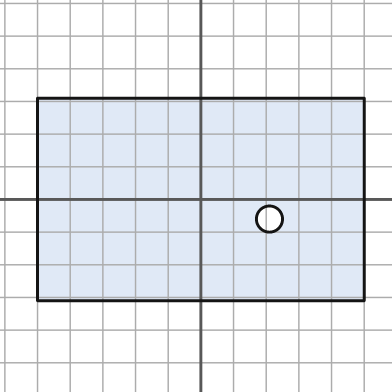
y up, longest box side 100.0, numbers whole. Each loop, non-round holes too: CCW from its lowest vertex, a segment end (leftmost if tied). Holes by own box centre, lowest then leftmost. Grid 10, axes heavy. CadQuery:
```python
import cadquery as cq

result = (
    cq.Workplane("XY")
    .moveTo(-50.0, -31.0)
    .lineTo(50.0, -31.0)
    .lineTo(50.0, 31.0)
    .lineTo(-50.0, 31.0)
    .close()
    .moveTo(21.0, -6.0)
    .circle(4.0)
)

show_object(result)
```